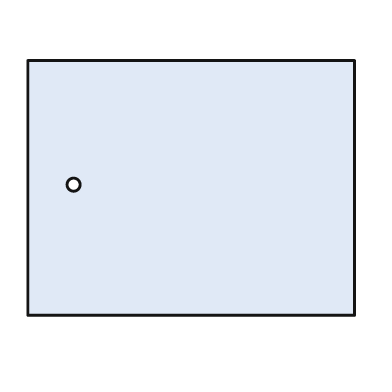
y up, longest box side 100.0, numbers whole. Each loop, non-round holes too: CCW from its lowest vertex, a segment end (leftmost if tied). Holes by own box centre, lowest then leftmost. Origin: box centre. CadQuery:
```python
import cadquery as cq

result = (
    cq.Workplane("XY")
    .moveTo(-50.0, -39.0)
    .lineTo(50.0, -39.0)
    .lineTo(50.0, 39.0)
    .lineTo(-50.0, 39.0)
    .close()
    .moveTo(-36.0, 1.0)
    .circle(2.0)
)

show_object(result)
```